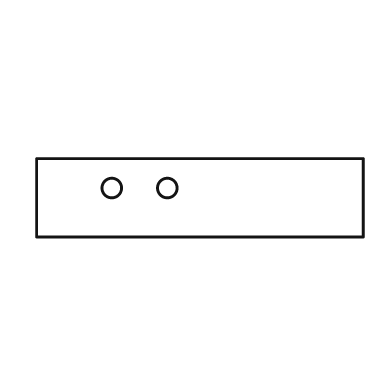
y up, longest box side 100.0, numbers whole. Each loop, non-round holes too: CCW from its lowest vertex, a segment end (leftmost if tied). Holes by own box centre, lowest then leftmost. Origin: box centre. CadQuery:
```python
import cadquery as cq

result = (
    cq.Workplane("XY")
    .moveTo(-50.0, -12.0)
    .lineTo(50.0, -12.0)
    .lineTo(50.0, 12.0)
    .lineTo(-50.0, 12.0)
    .close()
    .moveTo(-27.0, 3.0)
    .circle(3.0)
    .moveTo(-10.0, 3.0)
    .circle(3.0)
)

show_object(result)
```